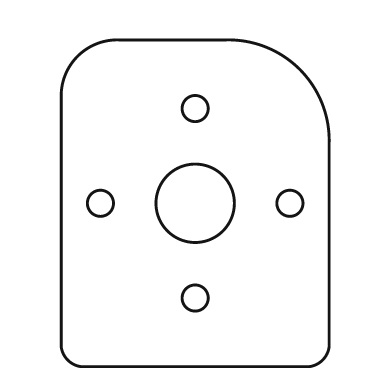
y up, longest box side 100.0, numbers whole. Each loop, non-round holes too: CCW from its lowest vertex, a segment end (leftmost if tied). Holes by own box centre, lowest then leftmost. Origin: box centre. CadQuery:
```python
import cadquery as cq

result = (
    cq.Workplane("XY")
    .moveTo(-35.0, -50.0)
    .lineTo(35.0, -50.0)
    .threePointArc((39.0, -48.0), (41.0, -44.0))
    .lineTo(41.0, 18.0)
    .threePointArc((32.0, 41.0), (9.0, 50.0))
    .lineTo(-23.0, 50.0)
    .threePointArc((-36.0, 45.0), (-41.0, 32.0))
    .lineTo(-41.0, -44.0)
    .threePointArc((-39.0, -48.0), (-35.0, -50.0))
    .close()
    .moveTo(0.0, -29.0)
    .circle(4.0)
    .moveTo(-29.0, 0.0)
    .circle(4.0)
    .moveTo(0.0, 0.0)
    .circle(12.0)
    .moveTo(29.0, 0.0)
    .circle(4.0)
    .moveTo(0.0, 29.0)
    .circle(4.0)
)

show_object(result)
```